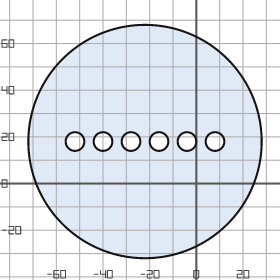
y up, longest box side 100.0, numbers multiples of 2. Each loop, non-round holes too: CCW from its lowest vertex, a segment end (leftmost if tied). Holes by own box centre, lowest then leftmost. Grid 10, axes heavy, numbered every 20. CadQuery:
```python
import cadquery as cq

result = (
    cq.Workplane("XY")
    .moveTo(-22.0, 18.0)
    .circle(50.0)
    .moveTo(-52.0, 18.0)
    .circle(4.0)
    .moveTo(-40.0, 18.0)
    .circle(4.0)
    .moveTo(-28.0, 18.0)
    .circle(4.0)
    .moveTo(-16.0, 18.0)
    .circle(4.0)
    .moveTo(-4.0, 18.0)
    .circle(4.0)
    .moveTo(8.0, 18.0)
    .circle(4.0)
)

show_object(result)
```